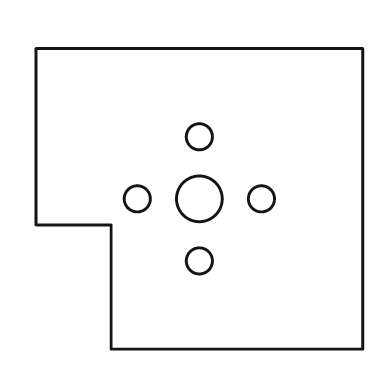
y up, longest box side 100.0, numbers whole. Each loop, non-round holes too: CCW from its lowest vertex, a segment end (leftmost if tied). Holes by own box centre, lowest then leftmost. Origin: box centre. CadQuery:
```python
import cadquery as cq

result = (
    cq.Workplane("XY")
    .moveTo(-27.0, -46.0)
    .lineTo(50.0, -46.0)
    .lineTo(50.0, 46.0)
    .lineTo(-50.0, 46.0)
    .lineTo(-50.0, -8.0)
    .lineTo(-27.0, -8.0)
    .close()
    .moveTo(0.0, -19.0)
    .circle(4.0)
    .moveTo(-19.0, 0.0)
    .circle(4.0)
    .moveTo(0.0, 0.0)
    .circle(7.0)
    .moveTo(19.0, 0.0)
    .circle(4.0)
    .moveTo(0.0, 19.0)
    .circle(4.0)
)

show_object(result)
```